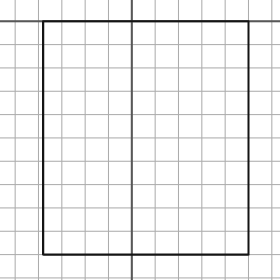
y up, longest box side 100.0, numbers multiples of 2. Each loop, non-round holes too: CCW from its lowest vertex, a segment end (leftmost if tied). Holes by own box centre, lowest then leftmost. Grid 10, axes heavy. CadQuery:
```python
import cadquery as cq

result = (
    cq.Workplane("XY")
    .moveTo(-38.0, -100.0)
    .lineTo(50.0, -100.0)
    .lineTo(50.0, 0.0)
    .lineTo(-38.0, 0.0)
    .close()
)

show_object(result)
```